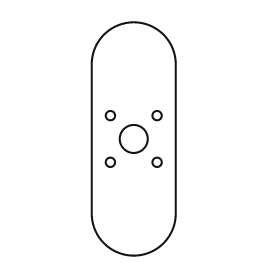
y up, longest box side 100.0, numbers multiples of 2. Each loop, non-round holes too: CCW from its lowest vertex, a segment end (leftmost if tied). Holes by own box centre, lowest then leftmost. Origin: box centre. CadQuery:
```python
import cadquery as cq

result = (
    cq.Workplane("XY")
    .moveTo(-18.0, -32.0)
    .threePointArc((0.0, -50.0), (18.0, -32.0))
    .lineTo(18.0, 32.0)
    .threePointArc((0.0, 50.0), (-18.0, 32.0))
    .close()
    .moveTo(-10.0, -10.0)
    .circle(2.0)
    .moveTo(10.0, -10.0)
    .circle(2.0)
    .moveTo(0.0, 0.0)
    .circle(6.0)
    .moveTo(-10.0, 10.0)
    .circle(2.0)
    .moveTo(10.0, 10.0)
    .circle(2.0)
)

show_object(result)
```